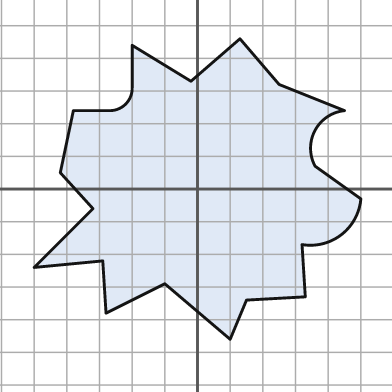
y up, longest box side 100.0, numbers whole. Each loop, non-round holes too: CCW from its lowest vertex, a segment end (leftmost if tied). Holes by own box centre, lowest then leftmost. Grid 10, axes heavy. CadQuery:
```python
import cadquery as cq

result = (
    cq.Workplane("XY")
    .moveTo(10.0, -46.0)
    .lineTo(15.0, -34.0)
    .lineTo(33.0, -33.0)
    .lineTo(32.0, -17.0)
    .threePointArc((44.0, -14.0), (50.0, -3.0))
    .lineTo(36.0, 7.0)
    .threePointArc((36.0, 18.0), (45.0, 24.0))
    .lineTo(25.0, 32.0)
    .lineTo(13.0, 46.0)
    .lineTo(-2.0, 33.0)
    .lineTo(-20.0, 44.0)
    .lineTo(-20.0, 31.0)
    .threePointArc((-22.0, 26.0), (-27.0, 24.0))
    .lineTo(-38.0, 24.0)
    .lineTo(-42.0, 5.0)
    .lineTo(-32.0, -6.0)
    .lineTo(-50.0, -24.0)
    .lineTo(-29.0, -22.0)
    .lineTo(-28.0, -38.0)
    .lineTo(-10.0, -29.0)
    .close()
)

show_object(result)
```